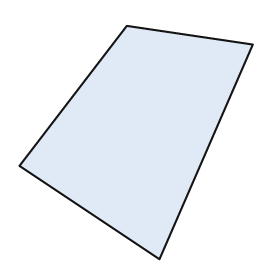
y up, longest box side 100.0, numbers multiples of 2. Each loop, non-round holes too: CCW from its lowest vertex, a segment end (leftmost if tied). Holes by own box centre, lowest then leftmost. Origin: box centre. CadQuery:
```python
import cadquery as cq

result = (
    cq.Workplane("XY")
    .moveTo(10.0, -50.0)
    .lineTo(50.0, 42.0)
    .lineTo(-4.0, 50.0)
    .lineTo(-50.0, -10.0)
    .close()
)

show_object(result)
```